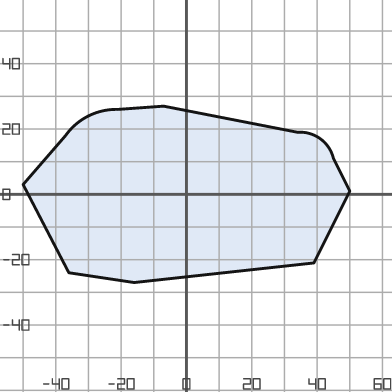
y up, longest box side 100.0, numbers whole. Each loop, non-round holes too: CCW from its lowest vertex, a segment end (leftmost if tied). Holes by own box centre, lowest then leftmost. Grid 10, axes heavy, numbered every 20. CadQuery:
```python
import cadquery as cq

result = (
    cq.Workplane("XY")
    .moveTo(-16.0, -27.0)
    .lineTo(39.0, -21.0)
    .lineTo(50.0, 1.0)
    .lineTo(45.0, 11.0)
    .threePointArc((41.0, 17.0), (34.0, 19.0))
    .lineTo(-7.0, 27.0)
    .lineTo(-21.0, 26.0)
    .threePointArc((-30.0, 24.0), (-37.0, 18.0))
    .lineTo(-50.0, 3.0)
    .lineTo(-36.0, -24.0)
    .close()
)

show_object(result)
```